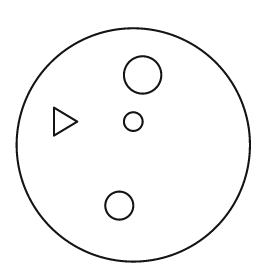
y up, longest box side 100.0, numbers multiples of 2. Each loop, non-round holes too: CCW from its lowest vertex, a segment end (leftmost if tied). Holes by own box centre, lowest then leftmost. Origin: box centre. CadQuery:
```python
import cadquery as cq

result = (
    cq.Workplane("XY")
    .moveTo(0.0, 0.0)
    .circle(50.0)
    .moveTo(-6.0, -26.0)
    .circle(6.0)
    .moveTo(-34.0, 4.0)
    .lineTo(-24.0, 10.0)
    .lineTo(-34.0, 16.0)
    .close()
    .moveTo(0.0, 10.0)
    .circle(4.0)
    .moveTo(4.0, 30.0)
    .circle(8.0)
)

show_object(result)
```